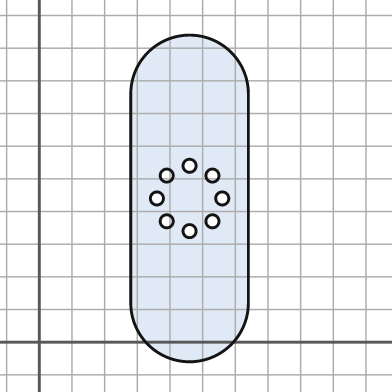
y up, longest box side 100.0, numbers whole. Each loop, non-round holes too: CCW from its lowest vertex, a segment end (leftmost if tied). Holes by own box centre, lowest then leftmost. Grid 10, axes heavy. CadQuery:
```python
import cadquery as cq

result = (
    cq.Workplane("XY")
    .moveTo(28.0, 12.0)
    .threePointArc((46.0, -6.0), (64.0, 12.0))
    .lineTo(64.0, 76.0)
    .threePointArc((46.0, 94.0), (28.0, 76.0))
    .close()
    .moveTo(46.0, 34.0)
    .circle(2.0)
    .moveTo(39.0, 37.0)
    .circle(2.0)
    .moveTo(53.0, 37.0)
    .circle(2.0)
    .moveTo(36.0, 44.0)
    .circle(2.0)
    .moveTo(56.0, 44.0)
    .circle(2.0)
    .moveTo(39.0, 51.0)
    .circle(2.0)
    .moveTo(53.0, 51.0)
    .circle(2.0)
    .moveTo(46.0, 54.0)
    .circle(2.0)
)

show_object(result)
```